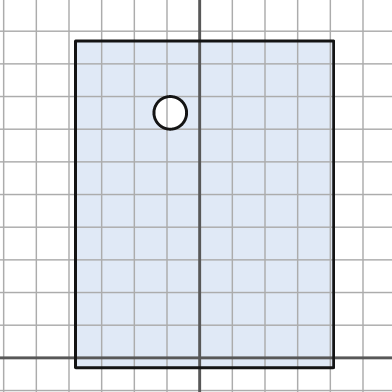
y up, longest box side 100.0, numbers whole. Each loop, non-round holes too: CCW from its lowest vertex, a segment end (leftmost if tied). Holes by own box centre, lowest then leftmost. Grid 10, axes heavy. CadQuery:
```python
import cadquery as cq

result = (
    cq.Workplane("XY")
    .moveTo(-38.0, -3.0)
    .lineTo(41.0, -3.0)
    .lineTo(41.0, 97.0)
    .lineTo(-38.0, 97.0)
    .close()
    .moveTo(-9.0, 75.0)
    .circle(5.0)
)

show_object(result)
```